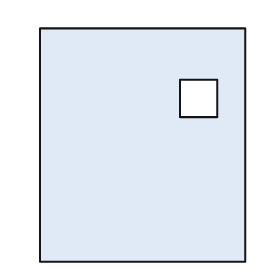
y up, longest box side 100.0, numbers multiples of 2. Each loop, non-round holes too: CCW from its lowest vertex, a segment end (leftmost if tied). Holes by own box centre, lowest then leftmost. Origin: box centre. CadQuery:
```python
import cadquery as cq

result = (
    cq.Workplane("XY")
    .moveTo(-44.0, -50.0)
    .lineTo(44.0, -50.0)
    .lineTo(44.0, 50.0)
    .lineTo(-44.0, 50.0)
    .close()
    .moveTo(16.0, 12.0)
    .lineTo(32.0, 12.0)
    .lineTo(32.0, 28.0)
    .lineTo(16.0, 28.0)
    .close()
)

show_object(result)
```